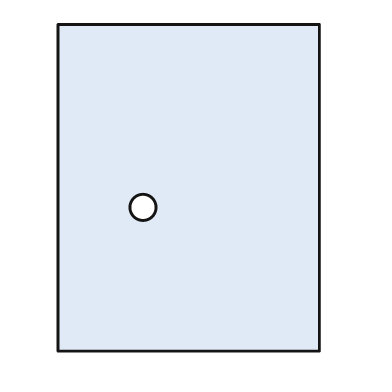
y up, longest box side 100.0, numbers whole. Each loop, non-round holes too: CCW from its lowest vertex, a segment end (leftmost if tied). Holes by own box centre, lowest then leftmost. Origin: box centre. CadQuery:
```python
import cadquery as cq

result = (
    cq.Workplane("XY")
    .moveTo(-40.0, -50.0)
    .lineTo(40.0, -50.0)
    .lineTo(40.0, 50.0)
    .lineTo(-40.0, 50.0)
    .close()
    .moveTo(-14.0, -6.0)
    .circle(4.0)
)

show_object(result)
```